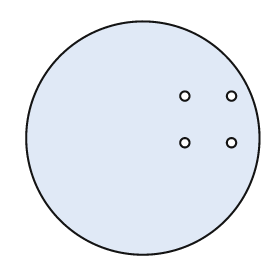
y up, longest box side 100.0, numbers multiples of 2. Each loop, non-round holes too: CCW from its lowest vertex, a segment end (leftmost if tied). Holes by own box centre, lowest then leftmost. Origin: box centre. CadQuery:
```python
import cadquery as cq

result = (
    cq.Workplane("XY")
    .moveTo(0.0, 0.0)
    .circle(50.0)
    .moveTo(18.0, -2.0)
    .circle(2.0)
    .moveTo(38.0, -2.0)
    .circle(2.0)
    .moveTo(18.0, 18.0)
    .circle(2.0)
    .moveTo(38.0, 18.0)
    .circle(2.0)
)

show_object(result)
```